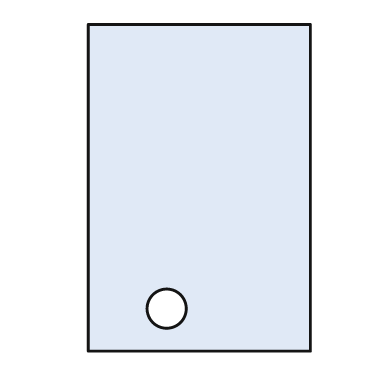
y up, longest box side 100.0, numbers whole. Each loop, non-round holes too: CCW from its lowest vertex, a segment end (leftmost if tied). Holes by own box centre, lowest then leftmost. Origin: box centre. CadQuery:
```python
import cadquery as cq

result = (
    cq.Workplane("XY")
    .moveTo(-34.0, -50.0)
    .lineTo(34.0, -50.0)
    .lineTo(34.0, 50.0)
    .lineTo(-34.0, 50.0)
    .close()
    .moveTo(-10.0, -37.0)
    .circle(6.0)
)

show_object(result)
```